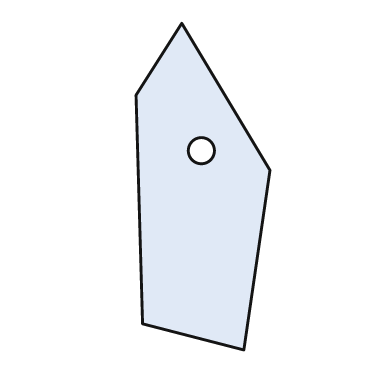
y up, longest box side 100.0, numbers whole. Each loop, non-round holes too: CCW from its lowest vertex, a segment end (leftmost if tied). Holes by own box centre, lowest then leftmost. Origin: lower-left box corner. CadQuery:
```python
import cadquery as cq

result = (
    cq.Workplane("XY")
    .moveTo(33.0, 0.0)
    .lineTo(41.0, 55.0)
    .lineTo(14.0, 100.0)
    .lineTo(0.0, 78.0)
    .lineTo(2.0, 8.0)
    .close()
    .moveTo(20.0, 61.0)
    .circle(4.0)
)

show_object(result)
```